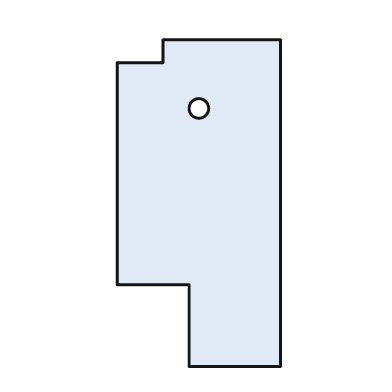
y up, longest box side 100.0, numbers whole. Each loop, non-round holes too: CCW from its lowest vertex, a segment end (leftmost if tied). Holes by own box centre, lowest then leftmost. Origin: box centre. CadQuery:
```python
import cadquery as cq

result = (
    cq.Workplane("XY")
    .moveTo(-3.0, -50.0)
    .lineTo(25.0, -50.0)
    .lineTo(25.0, 50.0)
    .lineTo(-11.0, 50.0)
    .lineTo(-11.0, 43.0)
    .lineTo(-25.0, 43.0)
    .lineTo(-25.0, -25.0)
    .lineTo(-3.0, -25.0)
    .close()
    .moveTo(0.0, 29.0)
    .circle(3.0)
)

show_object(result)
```